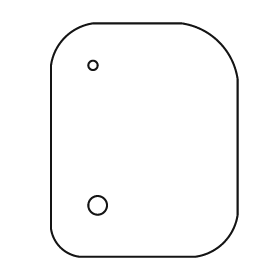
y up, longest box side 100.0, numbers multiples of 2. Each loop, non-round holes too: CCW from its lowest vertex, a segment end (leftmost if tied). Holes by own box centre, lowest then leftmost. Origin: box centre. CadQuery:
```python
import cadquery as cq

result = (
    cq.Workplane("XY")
    .moveTo(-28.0, -50.0)
    .lineTo(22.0, -50.0)
    .threePointArc((34.0, -44.0), (40.0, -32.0))
    .lineTo(40.0, 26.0)
    .threePointArc((32.0, 42.0), (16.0, 50.0))
    .lineTo(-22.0, 50.0)
    .threePointArc((-34.0, 44.0), (-40.0, 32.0))
    .lineTo(-40.0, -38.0)
    .threePointArc((-36.0, -46.0), (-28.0, -50.0))
    .close()
    .moveTo(-20.0, -28.0)
    .circle(4.0)
    .moveTo(-22.0, 32.0)
    .circle(2.0)
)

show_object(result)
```